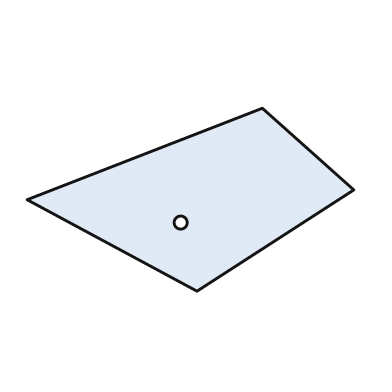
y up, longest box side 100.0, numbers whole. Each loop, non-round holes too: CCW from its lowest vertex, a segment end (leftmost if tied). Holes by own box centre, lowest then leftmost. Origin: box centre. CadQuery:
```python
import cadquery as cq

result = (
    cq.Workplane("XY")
    .moveTo(2.0, -28.0)
    .lineTo(50.0, 3.0)
    .lineTo(22.0, 28.0)
    .lineTo(-50.0, 0.0)
    .close()
    .moveTo(-3.0, -7.0)
    .circle(2.0)
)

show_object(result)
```